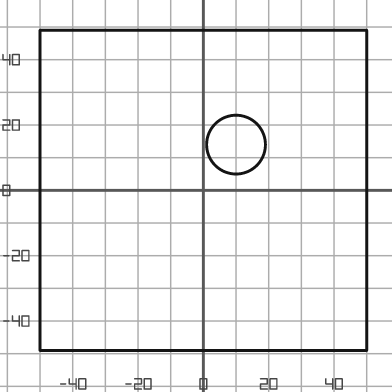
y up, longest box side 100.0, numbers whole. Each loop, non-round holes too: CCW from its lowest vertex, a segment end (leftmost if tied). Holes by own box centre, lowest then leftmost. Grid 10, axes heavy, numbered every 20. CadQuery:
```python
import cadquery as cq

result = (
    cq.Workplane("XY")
    .moveTo(-50.0, -49.0)
    .lineTo(50.0, -49.0)
    .lineTo(50.0, 49.0)
    .lineTo(-50.0, 49.0)
    .close()
    .moveTo(10.0, 14.0)
    .circle(9.0)
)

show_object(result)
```